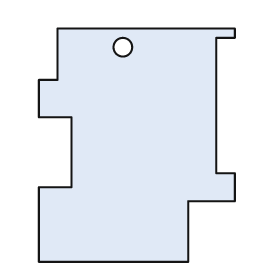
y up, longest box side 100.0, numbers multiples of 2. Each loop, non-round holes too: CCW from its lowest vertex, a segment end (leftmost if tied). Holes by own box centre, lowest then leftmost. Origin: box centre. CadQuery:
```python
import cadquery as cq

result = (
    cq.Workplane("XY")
    .moveTo(-42.0, -50.0)
    .lineTo(22.0, -50.0)
    .lineTo(22.0, -24.0)
    .lineTo(42.0, -24.0)
    .lineTo(42.0, -12.0)
    .lineTo(34.0, -12.0)
    .lineTo(34.0, 46.0)
    .lineTo(42.0, 46.0)
    .lineTo(42.0, 50.0)
    .lineTo(-34.0, 50.0)
    .lineTo(-34.0, 28.0)
    .lineTo(-42.0, 28.0)
    .lineTo(-42.0, 12.0)
    .lineTo(-28.0, 12.0)
    .lineTo(-28.0, -18.0)
    .lineTo(-42.0, -18.0)
    .close()
    .moveTo(-6.0, 42.0)
    .circle(4.0)
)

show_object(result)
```